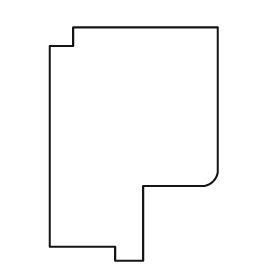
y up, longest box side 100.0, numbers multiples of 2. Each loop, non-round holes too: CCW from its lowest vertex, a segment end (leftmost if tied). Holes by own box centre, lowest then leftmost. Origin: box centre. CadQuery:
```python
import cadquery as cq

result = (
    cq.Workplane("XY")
    .moveTo(-8.0, -50.0)
    .lineTo(4.0, -50.0)
    .lineTo(4.0, -18.0)
    .lineTo(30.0, -18.0)
    .threePointArc((34.0, -16.0), (36.0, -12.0))
    .lineTo(36.0, 50.0)
    .lineTo(-26.0, 50.0)
    .lineTo(-26.0, 42.0)
    .lineTo(-36.0, 42.0)
    .lineTo(-36.0, -44.0)
    .lineTo(-8.0, -44.0)
    .close()
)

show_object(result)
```